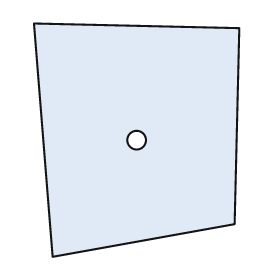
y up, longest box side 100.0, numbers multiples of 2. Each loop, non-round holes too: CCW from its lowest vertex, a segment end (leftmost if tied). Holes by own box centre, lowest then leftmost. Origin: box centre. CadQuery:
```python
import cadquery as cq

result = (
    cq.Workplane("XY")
    .moveTo(-36.0, -50.0)
    .lineTo(42.0, -36.0)
    .lineTo(44.0, 48.0)
    .lineTo(-44.0, 50.0)
    .close()
    .moveTo(0.0, 0.0)
    .circle(4.0)
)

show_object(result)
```